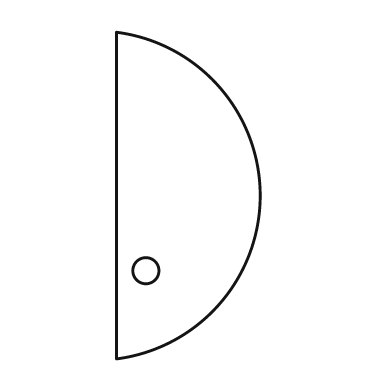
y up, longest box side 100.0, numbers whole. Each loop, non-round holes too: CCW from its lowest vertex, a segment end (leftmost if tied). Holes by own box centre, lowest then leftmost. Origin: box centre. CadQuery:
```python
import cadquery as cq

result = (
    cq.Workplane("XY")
    .moveTo(-22.0, -50.0)
    .threePointArc((22.0, 0.0), (-22.0, 50.0))
    .close()
    .moveTo(-13.0, -23.0)
    .circle(4.0)
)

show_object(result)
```